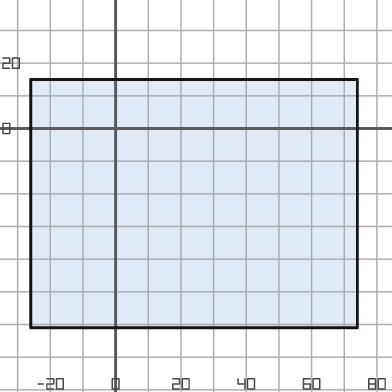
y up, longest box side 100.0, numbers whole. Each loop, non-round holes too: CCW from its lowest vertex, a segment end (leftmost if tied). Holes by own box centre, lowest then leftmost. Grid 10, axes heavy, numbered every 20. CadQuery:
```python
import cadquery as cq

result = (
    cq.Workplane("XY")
    .moveTo(-26.0, -61.0)
    .lineTo(74.0, -61.0)
    .lineTo(74.0, 15.0)
    .lineTo(-26.0, 15.0)
    .close()
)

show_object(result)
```